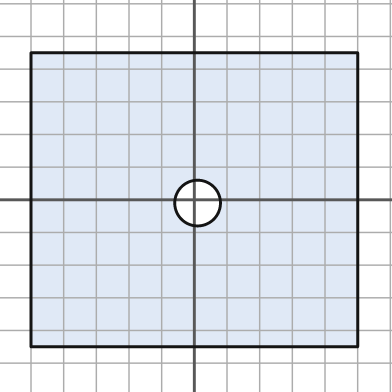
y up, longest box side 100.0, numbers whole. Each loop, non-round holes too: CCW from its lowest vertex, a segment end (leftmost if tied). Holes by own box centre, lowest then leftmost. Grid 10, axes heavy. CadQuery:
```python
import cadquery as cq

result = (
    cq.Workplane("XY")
    .moveTo(-50.0, -45.0)
    .lineTo(50.0, -45.0)
    .lineTo(50.0, 45.0)
    .lineTo(-50.0, 45.0)
    .close()
    .moveTo(1.0, -1.0)
    .circle(7.0)
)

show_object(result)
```